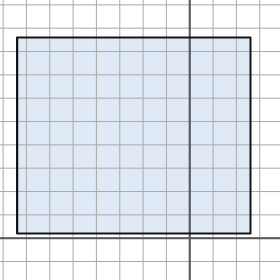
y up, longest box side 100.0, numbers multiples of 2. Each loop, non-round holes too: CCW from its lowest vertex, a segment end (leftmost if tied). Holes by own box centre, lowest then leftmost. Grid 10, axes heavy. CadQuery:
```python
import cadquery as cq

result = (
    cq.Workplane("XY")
    .moveTo(-74.0, 2.0)
    .lineTo(26.0, 2.0)
    .lineTo(26.0, 86.0)
    .lineTo(-74.0, 86.0)
    .close()
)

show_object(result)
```